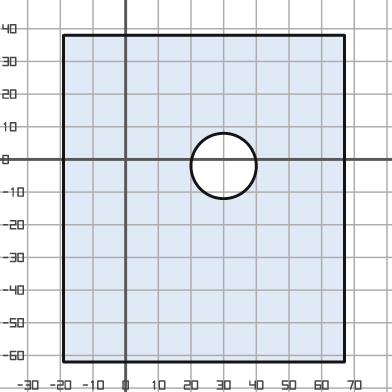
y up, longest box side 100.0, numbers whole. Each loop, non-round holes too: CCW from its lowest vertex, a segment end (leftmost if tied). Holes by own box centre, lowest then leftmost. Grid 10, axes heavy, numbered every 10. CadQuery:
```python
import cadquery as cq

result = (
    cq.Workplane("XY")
    .moveTo(-19.0, -62.0)
    .lineTo(67.0, -62.0)
    .lineTo(67.0, 38.0)
    .lineTo(-19.0, 38.0)
    .close()
    .moveTo(30.0, -2.0)
    .circle(10.0)
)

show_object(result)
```